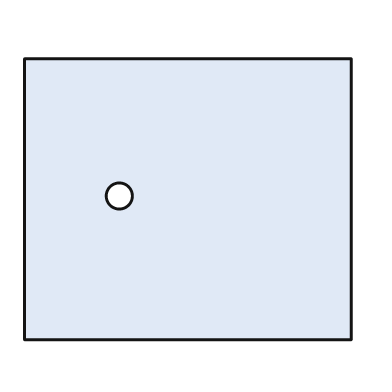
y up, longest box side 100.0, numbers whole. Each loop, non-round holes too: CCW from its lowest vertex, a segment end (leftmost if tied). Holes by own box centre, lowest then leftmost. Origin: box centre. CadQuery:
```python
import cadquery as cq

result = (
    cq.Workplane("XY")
    .moveTo(-50.0, -43.0)
    .lineTo(50.0, -43.0)
    .lineTo(50.0, 43.0)
    .lineTo(-50.0, 43.0)
    .close()
    .moveTo(-21.0, 1.0)
    .circle(4.0)
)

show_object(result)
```